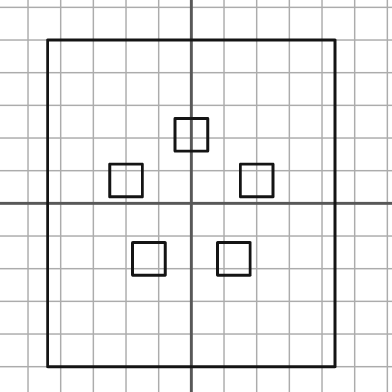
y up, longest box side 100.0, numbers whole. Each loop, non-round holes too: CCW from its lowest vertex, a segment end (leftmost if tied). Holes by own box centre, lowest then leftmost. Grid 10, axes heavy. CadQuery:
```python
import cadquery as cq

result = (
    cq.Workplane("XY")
    .moveTo(-44.0, -50.0)
    .lineTo(44.0, -50.0)
    .lineTo(44.0, 50.0)
    .lineTo(-44.0, 50.0)
    .close()
    .moveTo(-18.0, -22.0)
    .lineTo(-8.0, -22.0)
    .lineTo(-8.0, -12.0)
    .lineTo(-18.0, -12.0)
    .close()
    .moveTo(8.0, -22.0)
    .lineTo(18.0, -22.0)
    .lineTo(18.0, -12.0)
    .lineTo(8.0, -12.0)
    .close()
    .moveTo(-25.0, 2.0)
    .lineTo(-15.0, 2.0)
    .lineTo(-15.0, 12.0)
    .lineTo(-25.0, 12.0)
    .close()
    .moveTo(15.0, 2.0)
    .lineTo(25.0, 2.0)
    .lineTo(25.0, 12.0)
    .lineTo(15.0, 12.0)
    .close()
    .moveTo(-5.0, 16.0)
    .lineTo(5.0, 16.0)
    .lineTo(5.0, 26.0)
    .lineTo(-5.0, 26.0)
    .close()
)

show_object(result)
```